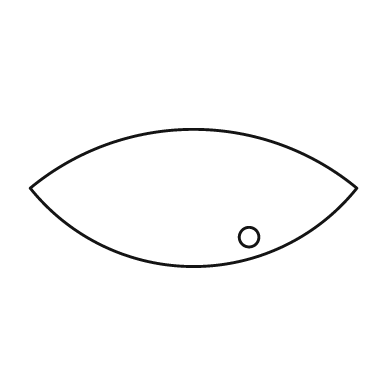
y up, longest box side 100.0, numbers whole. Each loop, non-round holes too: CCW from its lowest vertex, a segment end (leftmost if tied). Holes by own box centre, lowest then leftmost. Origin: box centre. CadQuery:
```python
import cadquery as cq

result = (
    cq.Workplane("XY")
    .moveTo(-50.0, 3.0)
    .threePointArc((0.0, -21.0), (50.0, 3.0))
    .threePointArc((0.0, 21.0), (-50.0, 3.0))
    .close()
    .moveTo(17.0, -12.0)
    .circle(3.0)
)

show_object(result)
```